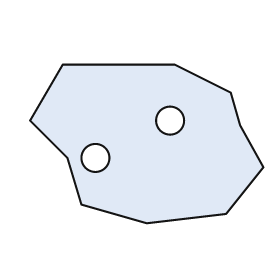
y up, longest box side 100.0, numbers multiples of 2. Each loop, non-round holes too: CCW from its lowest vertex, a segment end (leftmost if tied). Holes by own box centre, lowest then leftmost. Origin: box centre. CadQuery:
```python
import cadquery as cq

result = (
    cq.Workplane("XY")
    .moveTo(0.0, -34.0)
    .lineTo(34.0, -30.0)
    .lineTo(50.0, -10.0)
    .lineTo(40.0, 8.0)
    .lineTo(36.0, 22.0)
    .lineTo(12.0, 34.0)
    .lineTo(-36.0, 34.0)
    .lineTo(-50.0, 10.0)
    .lineTo(-34.0, -6.0)
    .lineTo(-28.0, -26.0)
    .close()
    .moveTo(-22.0, -6.0)
    .circle(6.0)
    .moveTo(10.0, 10.0)
    .circle(6.0)
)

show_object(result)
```